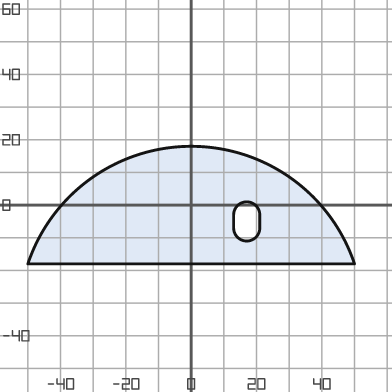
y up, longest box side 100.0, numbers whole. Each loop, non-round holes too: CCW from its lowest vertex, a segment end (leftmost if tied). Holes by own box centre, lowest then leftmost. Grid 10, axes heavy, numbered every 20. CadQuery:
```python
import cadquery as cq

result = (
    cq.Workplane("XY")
    .moveTo(-50.0, -18.0)
    .lineTo(50.0, -18.0)
    .threePointArc((0.0, 18.0), (-50.0, -18.0))
    .close()
    .moveTo(13.0, -7.0)
    .threePointArc((17.0, -11.0), (21.0, -7.0))
    .lineTo(21.0, -3.0)
    .threePointArc((17.0, 1.0), (13.0, -3.0))
    .close()
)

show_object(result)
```